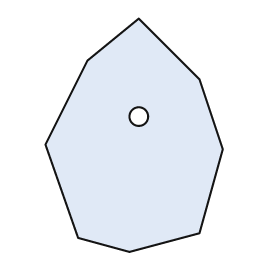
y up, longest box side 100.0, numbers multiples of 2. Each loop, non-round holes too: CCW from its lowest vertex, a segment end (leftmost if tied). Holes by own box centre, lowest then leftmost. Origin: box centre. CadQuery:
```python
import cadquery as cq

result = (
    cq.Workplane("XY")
    .moveTo(-2.0, -50.0)
    .lineTo(28.0, -42.0)
    .lineTo(38.0, -6.0)
    .lineTo(28.0, 24.0)
    .lineTo(2.0, 50.0)
    .lineTo(-20.0, 32.0)
    .lineTo(-38.0, -4.0)
    .lineTo(-24.0, -44.0)
    .close()
    .moveTo(2.0, 8.0)
    .circle(4.0)
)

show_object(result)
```